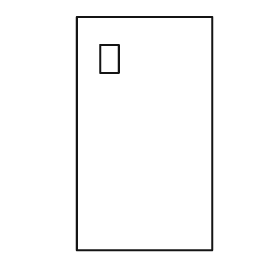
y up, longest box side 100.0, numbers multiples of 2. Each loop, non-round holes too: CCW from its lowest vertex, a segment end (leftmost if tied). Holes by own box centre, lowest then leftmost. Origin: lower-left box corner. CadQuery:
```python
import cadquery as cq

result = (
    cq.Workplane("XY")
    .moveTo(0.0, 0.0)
    .lineTo(58.0, 0.0)
    .lineTo(58.0, 100.0)
    .lineTo(0.0, 100.0)
    .close()
    .moveTo(10.0, 76.0)
    .lineTo(18.0, 76.0)
    .lineTo(18.0, 88.0)
    .lineTo(10.0, 88.0)
    .close()
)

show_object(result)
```